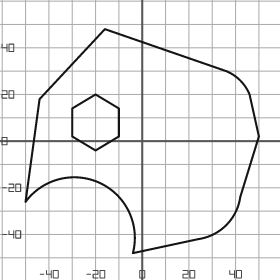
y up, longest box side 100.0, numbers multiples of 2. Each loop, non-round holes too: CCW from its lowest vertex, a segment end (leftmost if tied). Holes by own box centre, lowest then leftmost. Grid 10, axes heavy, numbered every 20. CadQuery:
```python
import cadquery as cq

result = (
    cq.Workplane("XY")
    .moveTo(-4.0, -48.0)
    .lineTo(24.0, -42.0)
    .threePointArc((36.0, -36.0), (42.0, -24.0))
    .lineTo(50.0, 2.0)
    .lineTo(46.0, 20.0)
    .threePointArc((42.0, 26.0), (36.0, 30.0))
    .lineTo(-16.0, 48.0)
    .lineTo(-44.0, 18.0)
    .lineTo(-50.0, -26.0)
    .threePointArc((-18.0, -18.0), (-4.0, -48.0))
    .close()
    .moveTo(-20.0, -4.0)
    .lineTo(-10.0, 2.0)
    .lineTo(-10.0, 14.0)
    .lineTo(-20.0, 20.0)
    .lineTo(-30.0, 14.0)
    .lineTo(-30.0, 2.0)
    .close()
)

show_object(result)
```